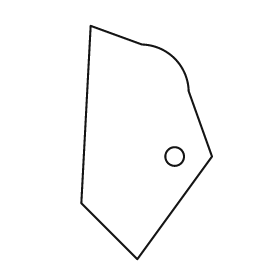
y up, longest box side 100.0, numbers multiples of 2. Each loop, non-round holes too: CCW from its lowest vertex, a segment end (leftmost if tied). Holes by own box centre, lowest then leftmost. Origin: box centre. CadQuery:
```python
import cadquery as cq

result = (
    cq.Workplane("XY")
    .moveTo(-4.0, -50.0)
    .lineTo(28.0, -6.0)
    .lineTo(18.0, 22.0)
    .threePointArc((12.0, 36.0), (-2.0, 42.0))
    .lineTo(-24.0, 50.0)
    .lineTo(-28.0, -26.0)
    .close()
    .moveTo(12.0, -6.0)
    .circle(4.0)
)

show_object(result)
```